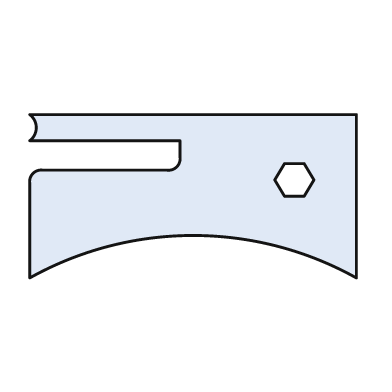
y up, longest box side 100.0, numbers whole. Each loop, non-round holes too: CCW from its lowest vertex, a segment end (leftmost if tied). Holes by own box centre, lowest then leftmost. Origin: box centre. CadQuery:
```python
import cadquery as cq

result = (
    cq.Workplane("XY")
    .moveTo(-50.0, -25.0)
    .threePointArc((0.0, -12.0), (50.0, -25.0))
    .lineTo(50.0, 25.0)
    .lineTo(-50.0, 25.0)
    .threePointArc((-48.0, 21.0), (-50.0, 17.0))
    .lineTo(-4.0, 17.0)
    .lineTo(-4.0, 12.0)
    .threePointArc((-5.0, 9.0), (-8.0, 8.0))
    .lineTo(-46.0, 8.0)
    .threePointArc((-49.0, 7.0), (-50.0, 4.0))
    .close()
    .moveTo(28.0, 0.0)
    .lineTo(34.0, 0.0)
    .lineTo(37.0, 5.0)
    .lineTo(34.0, 10.0)
    .lineTo(28.0, 10.0)
    .lineTo(25.0, 5.0)
    .close()
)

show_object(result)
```